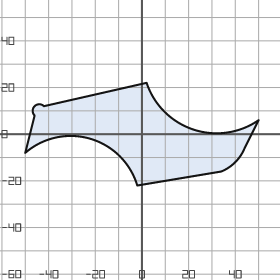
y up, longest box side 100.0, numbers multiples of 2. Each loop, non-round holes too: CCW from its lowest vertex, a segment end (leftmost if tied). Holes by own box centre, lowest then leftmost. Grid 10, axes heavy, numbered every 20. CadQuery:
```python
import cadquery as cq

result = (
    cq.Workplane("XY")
    .moveTo(-2.0, -22.0)
    .lineTo(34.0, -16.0)
    .threePointArc((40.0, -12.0), (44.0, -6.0))
    .lineTo(50.0, 6.0)
    .threePointArc((22.0, 2.0), (2.0, 22.0))
    .lineTo(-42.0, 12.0)
    .threePointArc((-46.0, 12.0), (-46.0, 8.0))
    .lineTo(-50.0, -8.0)
    .threePointArc((-22.0, -2.0), (-2.0, -22.0))
    .close()
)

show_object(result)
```